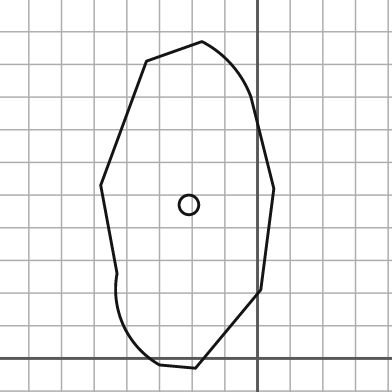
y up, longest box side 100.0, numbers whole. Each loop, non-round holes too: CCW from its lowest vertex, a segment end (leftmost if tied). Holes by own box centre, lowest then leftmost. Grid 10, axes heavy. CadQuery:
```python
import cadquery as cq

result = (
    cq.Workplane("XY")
    .moveTo(-19.0, -3.0)
    .lineTo(1.0, 21.0)
    .lineTo(5.0, 52.0)
    .lineTo(-2.0, 80.0)
    .threePointArc((-8.0, 90.0), (-17.0, 97.0))
    .lineTo(-34.0, 91.0)
    .lineTo(-48.0, 53.0)
    .lineTo(-43.0, 26.0)
    .threePointArc((-41.0, 10.0), (-30.0, -2.0))
    .close()
    .moveTo(-21.0, 47.0)
    .circle(3.0)
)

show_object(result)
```